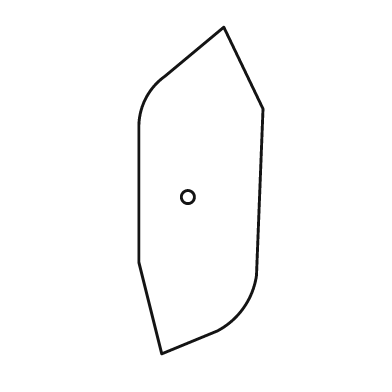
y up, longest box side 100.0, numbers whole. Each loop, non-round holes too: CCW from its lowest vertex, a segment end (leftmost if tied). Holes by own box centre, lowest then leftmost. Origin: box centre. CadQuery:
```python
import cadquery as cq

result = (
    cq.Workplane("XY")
    .moveTo(-12.0, -50.0)
    .lineTo(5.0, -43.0)
    .threePointArc((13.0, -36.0), (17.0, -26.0))
    .lineTo(19.0, 25.0)
    .lineTo(7.0, 50.0)
    .lineTo(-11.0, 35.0)
    .threePointArc((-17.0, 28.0), (-19.0, 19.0))
    .lineTo(-19.0, -22.0)
    .close()
    .moveTo(-4.0, -2.0)
    .circle(2.0)
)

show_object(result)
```